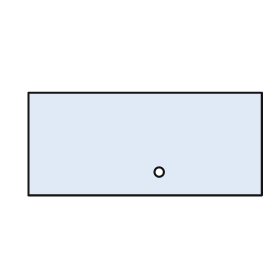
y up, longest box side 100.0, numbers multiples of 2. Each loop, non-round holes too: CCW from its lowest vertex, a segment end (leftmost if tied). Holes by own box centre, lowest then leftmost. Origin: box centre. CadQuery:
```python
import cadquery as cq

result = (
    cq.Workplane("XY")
    .moveTo(-50.0, -22.0)
    .lineTo(50.0, -22.0)
    .lineTo(50.0, 22.0)
    .lineTo(-50.0, 22.0)
    .close()
    .moveTo(6.0, -12.0)
    .circle(2.0)
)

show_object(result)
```